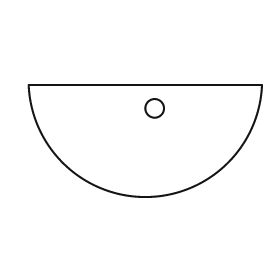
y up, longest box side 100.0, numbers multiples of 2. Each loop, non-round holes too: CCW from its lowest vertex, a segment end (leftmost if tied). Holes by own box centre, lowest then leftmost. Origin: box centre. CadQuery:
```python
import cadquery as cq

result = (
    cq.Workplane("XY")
    .moveTo(-50.0, 24.0)
    .threePointArc((0.0, -24.0), (50.0, 24.0))
    .close()
    .moveTo(4.0, 14.0)
    .circle(4.0)
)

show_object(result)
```